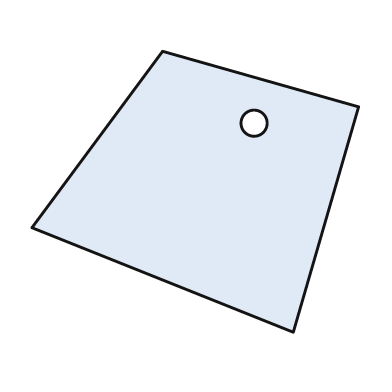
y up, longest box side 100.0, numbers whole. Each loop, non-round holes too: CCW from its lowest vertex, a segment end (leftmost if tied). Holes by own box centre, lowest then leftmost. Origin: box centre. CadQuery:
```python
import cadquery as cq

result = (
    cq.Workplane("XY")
    .moveTo(30.0, -43.0)
    .lineTo(50.0, 26.0)
    .lineTo(-10.0, 43.0)
    .lineTo(-50.0, -11.0)
    .close()
    .moveTo(18.0, 21.0)
    .circle(4.0)
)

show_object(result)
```